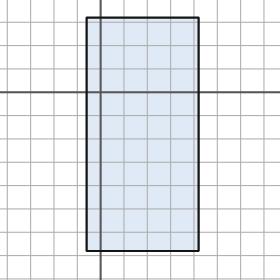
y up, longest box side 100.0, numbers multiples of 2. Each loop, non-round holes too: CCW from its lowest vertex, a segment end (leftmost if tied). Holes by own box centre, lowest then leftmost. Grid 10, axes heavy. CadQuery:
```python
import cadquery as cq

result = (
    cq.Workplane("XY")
    .moveTo(-6.0, -68.0)
    .lineTo(42.0, -68.0)
    .lineTo(42.0, 32.0)
    .lineTo(-6.0, 32.0)
    .close()
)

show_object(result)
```